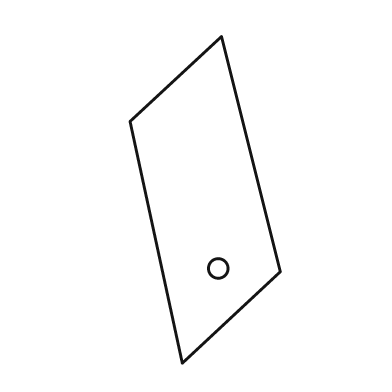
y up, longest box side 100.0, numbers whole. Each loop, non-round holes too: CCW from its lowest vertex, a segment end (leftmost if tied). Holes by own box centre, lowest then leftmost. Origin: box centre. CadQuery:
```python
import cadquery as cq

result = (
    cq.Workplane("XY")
    .moveTo(-7.0, -50.0)
    .lineTo(23.0, -22.0)
    .lineTo(5.0, 50.0)
    .lineTo(-23.0, 24.0)
    .close()
    .moveTo(4.0, -21.0)
    .circle(3.0)
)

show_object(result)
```